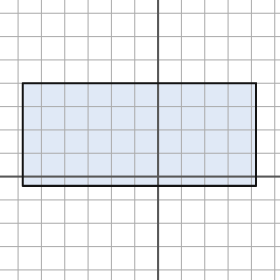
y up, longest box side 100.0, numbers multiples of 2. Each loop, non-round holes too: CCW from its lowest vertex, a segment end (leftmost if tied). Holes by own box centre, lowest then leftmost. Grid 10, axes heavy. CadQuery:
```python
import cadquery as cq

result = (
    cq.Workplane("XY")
    .moveTo(-58.0, -4.0)
    .lineTo(42.0, -4.0)
    .lineTo(42.0, 40.0)
    .lineTo(-58.0, 40.0)
    .close()
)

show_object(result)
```